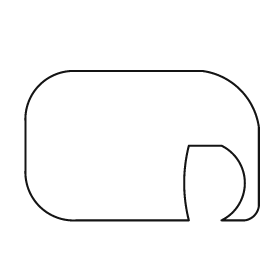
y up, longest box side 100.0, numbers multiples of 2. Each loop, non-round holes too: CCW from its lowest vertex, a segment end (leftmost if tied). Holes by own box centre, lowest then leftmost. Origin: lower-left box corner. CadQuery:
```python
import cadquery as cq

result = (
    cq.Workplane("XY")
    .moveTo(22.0, 0.0)
    .lineTo(70.0, 0.0)
    .threePointArc((68.0, 16.0), (70.0, 32.0))
    .lineTo(84.0, 32.0)
    .threePointArc((94.0, 16.0), (84.0, 0.0))
    .lineTo(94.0, 0.0)
    .threePointArc((98.0, 2.0), (100.0, 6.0))
    .lineTo(100.0, 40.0)
    .threePointArc((92.0, 56.0), (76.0, 64.0))
    .lineTo(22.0, 64.0)
    .threePointArc((6.0, 58.0), (0.0, 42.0))
    .lineTo(0.0, 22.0)
    .threePointArc((6.0, 6.0), (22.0, 0.0))
    .close()
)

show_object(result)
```